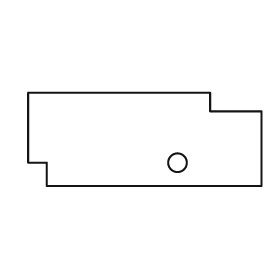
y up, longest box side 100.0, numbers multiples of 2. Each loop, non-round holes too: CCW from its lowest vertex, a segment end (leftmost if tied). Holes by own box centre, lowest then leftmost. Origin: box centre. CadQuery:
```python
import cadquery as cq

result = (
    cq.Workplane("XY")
    .moveTo(-42.0, -20.0)
    .lineTo(50.0, -20.0)
    .lineTo(50.0, 12.0)
    .lineTo(28.0, 12.0)
    .lineTo(28.0, 20.0)
    .lineTo(-50.0, 20.0)
    .lineTo(-50.0, -10.0)
    .lineTo(-42.0, -10.0)
    .close()
    .moveTo(14.0, -10.0)
    .circle(4.0)
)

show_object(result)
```